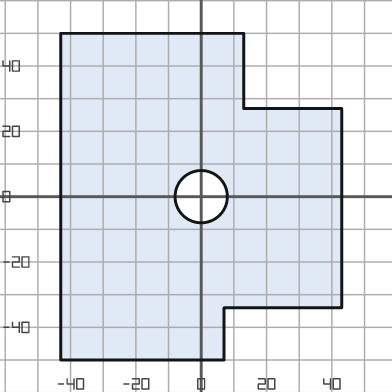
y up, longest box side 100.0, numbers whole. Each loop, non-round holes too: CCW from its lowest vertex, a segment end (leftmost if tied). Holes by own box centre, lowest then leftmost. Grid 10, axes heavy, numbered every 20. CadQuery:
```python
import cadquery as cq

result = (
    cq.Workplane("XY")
    .moveTo(-43.0, -50.0)
    .lineTo(7.0, -50.0)
    .lineTo(7.0, -34.0)
    .lineTo(43.0, -34.0)
    .lineTo(43.0, 27.0)
    .lineTo(13.0, 27.0)
    .lineTo(13.0, 50.0)
    .lineTo(-43.0, 50.0)
    .close()
    .moveTo(0.0, 0.0)
    .circle(8.0)
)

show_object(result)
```